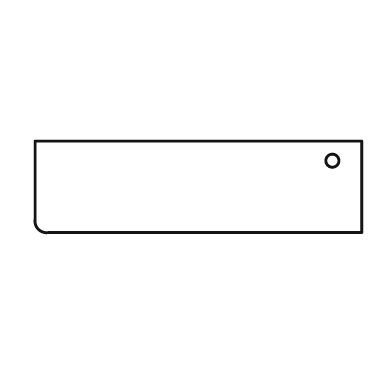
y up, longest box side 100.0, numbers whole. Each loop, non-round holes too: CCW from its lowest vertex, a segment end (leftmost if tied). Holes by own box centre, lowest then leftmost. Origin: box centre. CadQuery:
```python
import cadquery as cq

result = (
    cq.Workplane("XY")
    .moveTo(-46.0, -14.0)
    .lineTo(50.0, -14.0)
    .lineTo(50.0, 14.0)
    .lineTo(-50.0, 14.0)
    .lineTo(-50.0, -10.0)
    .threePointArc((-49.0, -13.0), (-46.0, -14.0))
    .close()
    .moveTo(41.0, 8.0)
    .circle(2.0)
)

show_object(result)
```